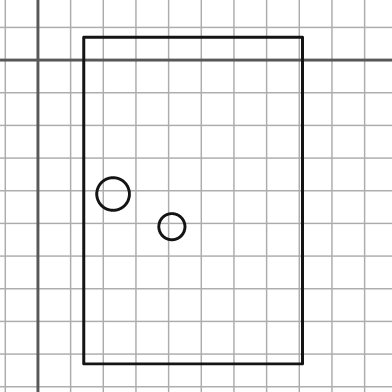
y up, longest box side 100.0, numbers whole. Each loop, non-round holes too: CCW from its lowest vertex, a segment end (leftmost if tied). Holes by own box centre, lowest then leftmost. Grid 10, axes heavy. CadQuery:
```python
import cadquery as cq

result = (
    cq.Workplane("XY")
    .moveTo(14.0, -93.0)
    .lineTo(81.0, -93.0)
    .lineTo(81.0, 7.0)
    .lineTo(14.0, 7.0)
    .close()
    .moveTo(41.0, -51.0)
    .circle(4.0)
    .moveTo(23.0, -41.0)
    .circle(5.0)
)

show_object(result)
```